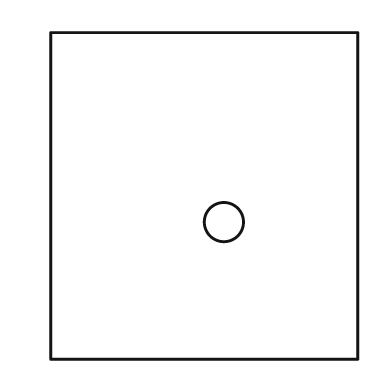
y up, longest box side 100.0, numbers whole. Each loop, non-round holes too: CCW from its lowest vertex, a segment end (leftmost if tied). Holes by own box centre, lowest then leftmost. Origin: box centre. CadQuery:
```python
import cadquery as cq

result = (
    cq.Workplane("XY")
    .moveTo(-47.0, -50.0)
    .lineTo(47.0, -50.0)
    .lineTo(47.0, 50.0)
    .lineTo(-47.0, 50.0)
    .close()
    .moveTo(6.0, -8.0)
    .circle(6.0)
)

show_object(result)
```